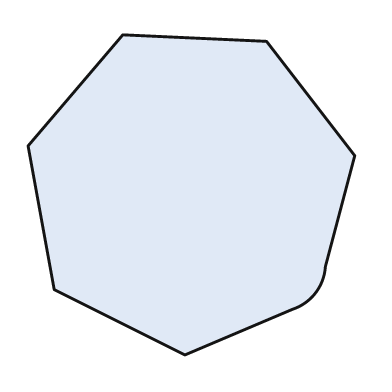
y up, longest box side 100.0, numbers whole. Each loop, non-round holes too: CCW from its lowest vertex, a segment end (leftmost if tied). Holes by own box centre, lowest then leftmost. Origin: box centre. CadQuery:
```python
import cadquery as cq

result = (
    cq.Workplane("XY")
    .moveTo(-2.0, -49.0)
    .lineTo(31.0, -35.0)
    .threePointArc((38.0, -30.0), (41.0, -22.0))
    .lineTo(50.0, 12.0)
    .lineTo(23.0, 47.0)
    .lineTo(-21.0, 49.0)
    .lineTo(-50.0, 15.0)
    .lineTo(-42.0, -29.0)
    .close()
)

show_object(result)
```